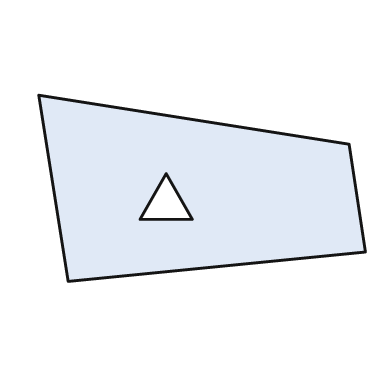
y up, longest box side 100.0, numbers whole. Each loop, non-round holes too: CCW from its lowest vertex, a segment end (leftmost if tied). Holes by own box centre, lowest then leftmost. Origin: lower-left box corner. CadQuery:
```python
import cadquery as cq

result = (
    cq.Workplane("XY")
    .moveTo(9.0, 0.0)
    .lineTo(100.0, 9.0)
    .lineTo(95.0, 42.0)
    .lineTo(0.0, 57.0)
    .close()
    .moveTo(31.0, 19.0)
    .lineTo(47.0, 19.0)
    .lineTo(39.0, 33.0)
    .close()
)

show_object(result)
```